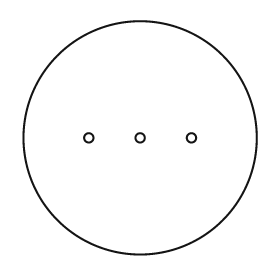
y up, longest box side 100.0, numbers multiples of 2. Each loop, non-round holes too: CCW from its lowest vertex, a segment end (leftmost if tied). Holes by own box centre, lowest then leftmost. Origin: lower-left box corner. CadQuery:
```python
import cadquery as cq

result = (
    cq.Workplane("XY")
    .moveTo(50.0, 50.0)
    .circle(50.0)
    .moveTo(28.0, 50.0)
    .circle(2.0)
    .moveTo(50.0, 50.0)
    .circle(2.0)
    .moveTo(72.0, 50.0)
    .circle(2.0)
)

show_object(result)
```